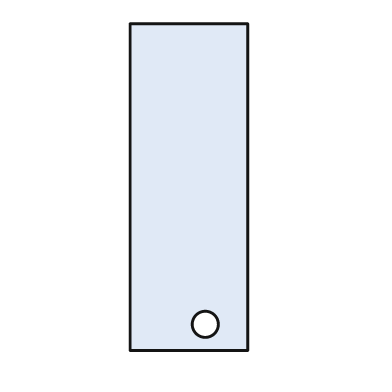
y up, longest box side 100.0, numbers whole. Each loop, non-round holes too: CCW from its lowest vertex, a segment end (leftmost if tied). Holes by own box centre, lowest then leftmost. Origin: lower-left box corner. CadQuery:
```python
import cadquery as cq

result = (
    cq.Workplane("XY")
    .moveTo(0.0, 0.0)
    .lineTo(36.0, 0.0)
    .lineTo(36.0, 100.0)
    .lineTo(0.0, 100.0)
    .close()
    .moveTo(23.0, 8.0)
    .circle(4.0)
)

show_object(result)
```